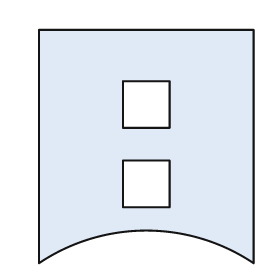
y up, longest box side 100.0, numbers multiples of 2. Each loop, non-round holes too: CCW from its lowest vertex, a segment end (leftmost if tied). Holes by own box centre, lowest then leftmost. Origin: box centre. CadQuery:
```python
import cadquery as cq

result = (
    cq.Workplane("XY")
    .moveTo(-46.0, -50.0)
    .threePointArc((0.0, -36.0), (46.0, -50.0))
    .lineTo(46.0, 50.0)
    .lineTo(-46.0, 50.0)
    .close()
    .moveTo(-10.0, -26.0)
    .lineTo(10.0, -26.0)
    .lineTo(10.0, -6.0)
    .lineTo(-10.0, -6.0)
    .close()
    .moveTo(-10.0, 8.0)
    .lineTo(10.0, 8.0)
    .lineTo(10.0, 28.0)
    .lineTo(-10.0, 28.0)
    .close()
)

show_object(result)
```